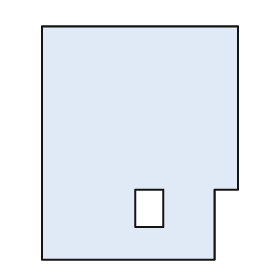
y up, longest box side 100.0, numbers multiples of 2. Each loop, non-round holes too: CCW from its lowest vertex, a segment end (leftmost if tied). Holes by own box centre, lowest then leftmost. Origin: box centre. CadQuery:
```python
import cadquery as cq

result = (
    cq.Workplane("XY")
    .moveTo(-42.0, -50.0)
    .lineTo(32.0, -50.0)
    .lineTo(32.0, -20.0)
    .lineTo(42.0, -20.0)
    .lineTo(42.0, 50.0)
    .lineTo(-42.0, 50.0)
    .close()
    .moveTo(-2.0, -36.0)
    .lineTo(10.0, -36.0)
    .lineTo(10.0, -20.0)
    .lineTo(-2.0, -20.0)
    .close()
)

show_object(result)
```